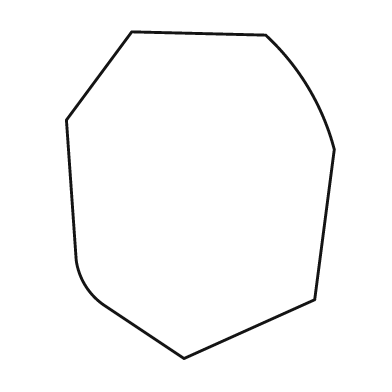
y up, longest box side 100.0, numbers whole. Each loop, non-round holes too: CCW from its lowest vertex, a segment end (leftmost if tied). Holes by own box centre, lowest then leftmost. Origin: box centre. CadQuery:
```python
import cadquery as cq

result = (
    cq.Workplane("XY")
    .moveTo(-5.0, -50.0)
    .lineTo(35.0, -32.0)
    .lineTo(41.0, 14.0)
    .threePointArc((33.0, 33.0), (20.0, 49.0))
    .lineTo(-21.0, 50.0)
    .lineTo(-41.0, 23.0)
    .lineTo(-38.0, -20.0)
    .threePointArc((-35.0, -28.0), (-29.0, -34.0))
    .close()
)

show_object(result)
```